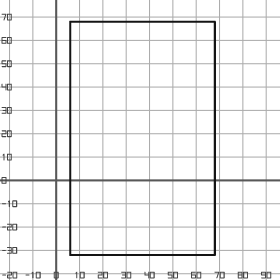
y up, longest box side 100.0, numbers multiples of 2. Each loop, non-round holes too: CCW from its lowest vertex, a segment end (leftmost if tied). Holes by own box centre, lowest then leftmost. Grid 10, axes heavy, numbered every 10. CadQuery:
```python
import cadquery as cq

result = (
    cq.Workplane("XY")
    .moveTo(6.0, -32.0)
    .lineTo(68.0, -32.0)
    .lineTo(68.0, 68.0)
    .lineTo(6.0, 68.0)
    .close()
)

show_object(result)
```